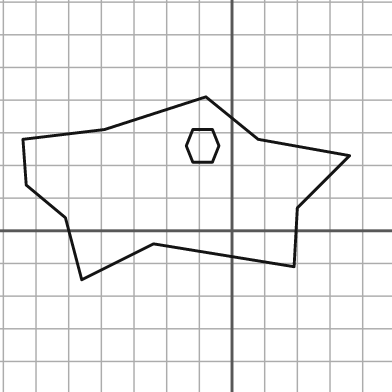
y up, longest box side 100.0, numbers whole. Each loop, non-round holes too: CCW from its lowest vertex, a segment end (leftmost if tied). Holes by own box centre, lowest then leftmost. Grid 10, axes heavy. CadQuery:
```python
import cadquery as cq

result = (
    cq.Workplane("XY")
    .moveTo(-46.0, -15.0)
    .lineTo(-24.0, -4.0)
    .lineTo(19.0, -11.0)
    .lineTo(20.0, 7.0)
    .lineTo(36.0, 23.0)
    .lineTo(8.0, 28.0)
    .lineTo(-8.0, 41.0)
    .lineTo(-39.0, 31.0)
    .lineTo(-64.0, 28.0)
    .lineTo(-63.0, 14.0)
    .lineTo(-51.0, 4.0)
    .close()
    .moveTo(-12.0, 21.0)
    .lineTo(-6.0, 21.0)
    .lineTo(-4.0, 26.0)
    .lineTo(-6.0, 31.0)
    .lineTo(-12.0, 31.0)
    .lineTo(-14.0, 26.0)
    .close()
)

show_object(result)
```